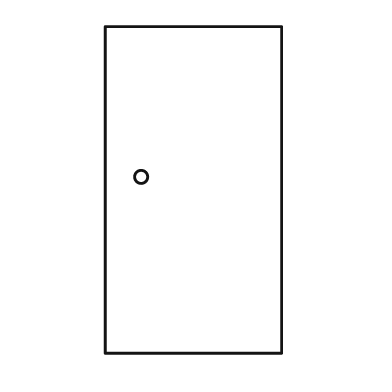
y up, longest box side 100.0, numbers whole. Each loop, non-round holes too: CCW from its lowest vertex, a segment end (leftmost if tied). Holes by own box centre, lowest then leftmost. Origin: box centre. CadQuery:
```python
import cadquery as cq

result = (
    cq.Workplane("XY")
    .moveTo(-27.0, -50.0)
    .lineTo(27.0, -50.0)
    .lineTo(27.0, 50.0)
    .lineTo(-27.0, 50.0)
    .close()
    .moveTo(-16.0, 4.0)
    .circle(2.0)
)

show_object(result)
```